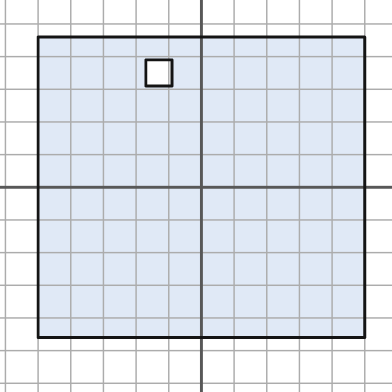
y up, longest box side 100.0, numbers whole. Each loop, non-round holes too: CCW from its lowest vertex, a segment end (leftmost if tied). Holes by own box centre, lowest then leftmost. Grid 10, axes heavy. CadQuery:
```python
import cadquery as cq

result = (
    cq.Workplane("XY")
    .moveTo(-50.0, -46.0)
    .lineTo(50.0, -46.0)
    .lineTo(50.0, 46.0)
    .lineTo(-50.0, 46.0)
    .close()
    .moveTo(-17.0, 31.0)
    .lineTo(-9.0, 31.0)
    .lineTo(-9.0, 39.0)
    .lineTo(-17.0, 39.0)
    .close()
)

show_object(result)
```